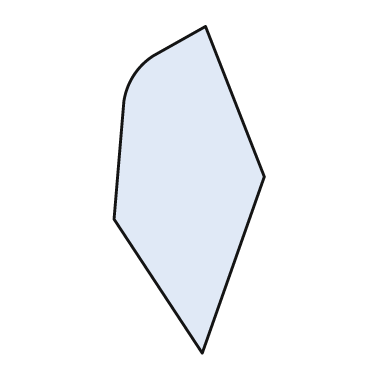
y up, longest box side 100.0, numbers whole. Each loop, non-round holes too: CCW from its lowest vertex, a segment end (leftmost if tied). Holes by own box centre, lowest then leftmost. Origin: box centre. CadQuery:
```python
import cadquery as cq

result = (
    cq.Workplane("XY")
    .moveTo(4.0, -50.0)
    .lineTo(23.0, 4.0)
    .lineTo(5.0, 50.0)
    .lineTo(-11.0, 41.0)
    .threePointArc((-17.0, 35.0), (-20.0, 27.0))
    .lineTo(-23.0, -9.0)
    .close()
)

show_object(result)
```